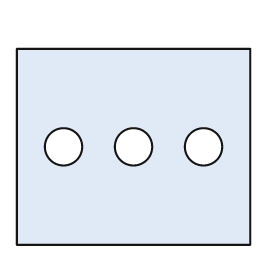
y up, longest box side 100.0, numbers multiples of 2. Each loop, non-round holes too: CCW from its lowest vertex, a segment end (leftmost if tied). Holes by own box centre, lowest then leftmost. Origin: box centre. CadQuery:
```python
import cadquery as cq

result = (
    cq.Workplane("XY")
    .moveTo(-50.0, -42.0)
    .lineTo(50.0, -42.0)
    .lineTo(50.0, 42.0)
    .lineTo(-50.0, 42.0)
    .close()
    .moveTo(-30.0, 0.0)
    .circle(8.0)
    .moveTo(0.0, 0.0)
    .circle(8.0)
    .moveTo(30.0, 0.0)
    .circle(8.0)
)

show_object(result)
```